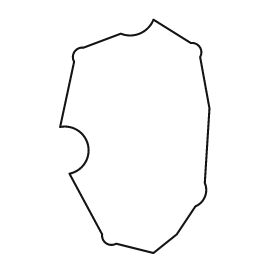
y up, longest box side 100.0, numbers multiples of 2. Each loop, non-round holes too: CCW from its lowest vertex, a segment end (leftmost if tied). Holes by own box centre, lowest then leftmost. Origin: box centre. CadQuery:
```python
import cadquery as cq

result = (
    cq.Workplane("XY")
    .moveTo(8.0, -50.0)
    .lineTo(18.0, -42.0)
    .lineTo(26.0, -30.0)
    .threePointArc((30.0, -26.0), (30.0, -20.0))
    .lineTo(32.0, 12.0)
    .lineTo(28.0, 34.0)
    .threePointArc((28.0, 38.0), (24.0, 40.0))
    .lineTo(8.0, 50.0)
    .threePointArc((2.0, 44.0), (-6.0, 44.0))
    .lineTo(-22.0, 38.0)
    .threePointArc((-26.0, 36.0), (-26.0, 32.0))
    .lineTo(-32.0, 4.0)
    .threePointArc((-20.0, -4.0), (-28.0, -16.0))
    .lineTo(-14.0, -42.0)
    .threePointArc((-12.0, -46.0), (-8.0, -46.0))
    .close()
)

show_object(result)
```